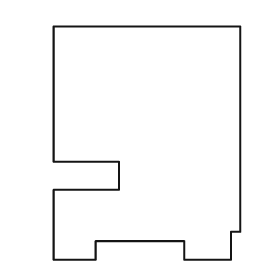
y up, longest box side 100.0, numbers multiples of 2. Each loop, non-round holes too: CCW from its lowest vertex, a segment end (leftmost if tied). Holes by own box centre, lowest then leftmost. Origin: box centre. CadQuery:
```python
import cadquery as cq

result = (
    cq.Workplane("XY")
    .moveTo(-40.0, -50.0)
    .lineTo(-22.0, -50.0)
    .lineTo(-22.0, -42.0)
    .lineTo(16.0, -42.0)
    .lineTo(16.0, -50.0)
    .lineTo(36.0, -50.0)
    .lineTo(36.0, -38.0)
    .lineTo(40.0, -38.0)
    .lineTo(40.0, 50.0)
    .lineTo(-40.0, 50.0)
    .lineTo(-40.0, -8.0)
    .lineTo(-12.0, -8.0)
    .lineTo(-12.0, -20.0)
    .lineTo(-40.0, -20.0)
    .close()
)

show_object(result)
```